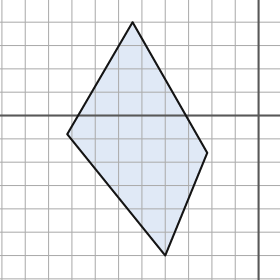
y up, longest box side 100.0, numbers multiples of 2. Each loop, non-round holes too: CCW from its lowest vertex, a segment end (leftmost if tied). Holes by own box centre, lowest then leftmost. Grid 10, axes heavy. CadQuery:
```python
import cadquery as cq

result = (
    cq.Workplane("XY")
    .moveTo(-40.0, -60.0)
    .lineTo(-22.0, -16.0)
    .lineTo(-54.0, 40.0)
    .lineTo(-82.0, -8.0)
    .close()
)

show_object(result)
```